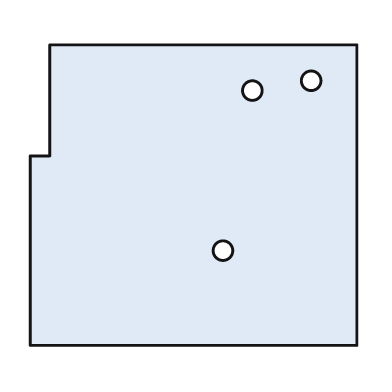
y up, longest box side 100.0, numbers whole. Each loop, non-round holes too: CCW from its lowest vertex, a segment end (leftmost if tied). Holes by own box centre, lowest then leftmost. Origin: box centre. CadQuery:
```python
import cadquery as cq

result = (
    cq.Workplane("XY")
    .moveTo(-50.0, -46.0)
    .lineTo(50.0, -46.0)
    .lineTo(50.0, 46.0)
    .lineTo(-44.0, 46.0)
    .lineTo(-44.0, 12.0)
    .lineTo(-50.0, 12.0)
    .close()
    .moveTo(9.0, -17.0)
    .circle(3.0)
    .moveTo(18.0, 32.0)
    .circle(3.0)
    .moveTo(36.0, 35.0)
    .circle(3.0)
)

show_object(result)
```